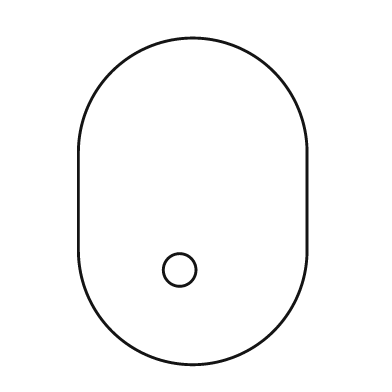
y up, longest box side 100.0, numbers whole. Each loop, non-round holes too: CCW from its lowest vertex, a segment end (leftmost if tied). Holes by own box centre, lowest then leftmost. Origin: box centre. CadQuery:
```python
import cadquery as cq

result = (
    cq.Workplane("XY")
    .moveTo(-35.0, -15.0)
    .threePointArc((0.0, -50.0), (35.0, -15.0))
    .lineTo(35.0, 15.0)
    .threePointArc((0.0, 50.0), (-35.0, 15.0))
    .close()
    .moveTo(-4.0, -21.0)
    .circle(5.0)
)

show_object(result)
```